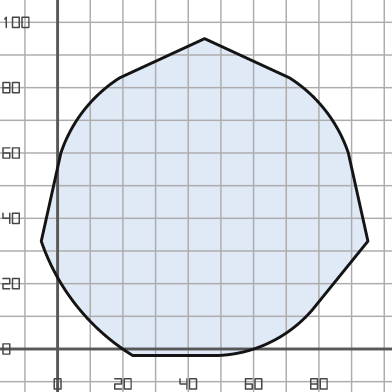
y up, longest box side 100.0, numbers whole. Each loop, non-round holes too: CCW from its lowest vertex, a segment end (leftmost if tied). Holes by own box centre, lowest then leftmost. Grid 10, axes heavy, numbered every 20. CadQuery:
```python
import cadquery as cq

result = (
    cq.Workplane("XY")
    .moveTo(23.0, -2.0)
    .lineTo(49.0, -2.0)
    .threePointArc((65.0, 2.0), (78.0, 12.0))
    .lineTo(95.0, 33.0)
    .lineTo(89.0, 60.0)
    .threePointArc((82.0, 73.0), (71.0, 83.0))
    .lineTo(45.0, 95.0)
    .lineTo(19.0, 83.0)
    .threePointArc((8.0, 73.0), (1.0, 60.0))
    .lineTo(-5.0, 33.0)
    .threePointArc((6.0, 13.0), (23.0, -2.0))
    .close()
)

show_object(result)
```